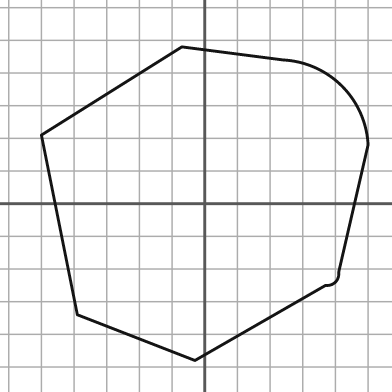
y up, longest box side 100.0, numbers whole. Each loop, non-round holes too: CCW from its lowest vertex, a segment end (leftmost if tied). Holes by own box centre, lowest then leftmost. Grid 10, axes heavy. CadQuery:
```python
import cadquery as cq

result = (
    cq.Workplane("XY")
    .moveTo(-3.0, -48.0)
    .lineTo(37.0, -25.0)
    .threePointArc((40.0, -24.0), (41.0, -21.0))
    .lineTo(50.0, 18.0)
    .threePointArc((42.0, 36.0), (24.0, 44.0))
    .lineTo(-7.0, 48.0)
    .lineTo(-50.0, 21.0)
    .lineTo(-39.0, -34.0)
    .close()
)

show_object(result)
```